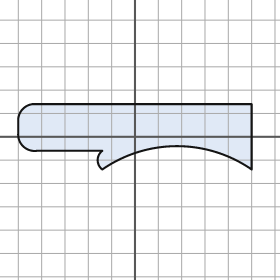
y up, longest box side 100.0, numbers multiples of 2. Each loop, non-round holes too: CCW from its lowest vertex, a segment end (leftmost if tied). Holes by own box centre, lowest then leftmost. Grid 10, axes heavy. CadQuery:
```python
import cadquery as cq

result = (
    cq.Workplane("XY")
    .moveTo(-14.0, -14.0)
    .threePointArc((18.0, -4.0), (50.0, -14.0))
    .lineTo(50.0, 14.0)
    .lineTo(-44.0, 14.0)
    .threePointArc((-48.0, 12.0), (-50.0, 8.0))
    .lineTo(-50.0, 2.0)
    .threePointArc((-48.0, -4.0), (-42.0, -6.0))
    .lineTo(-14.0, -6.0)
    .threePointArc((-16.0, -10.0), (-14.0, -14.0))
    .close()
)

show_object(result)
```